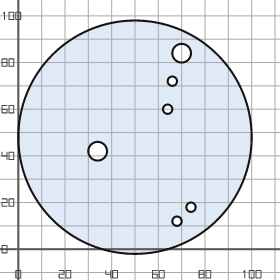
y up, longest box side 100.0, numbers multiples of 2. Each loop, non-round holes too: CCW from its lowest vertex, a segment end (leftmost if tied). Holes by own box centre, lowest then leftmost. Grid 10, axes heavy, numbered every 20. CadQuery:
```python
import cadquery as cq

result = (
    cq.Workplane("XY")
    .moveTo(50.0, 48.0)
    .circle(50.0)
    .moveTo(68.0, 12.0)
    .circle(2.0)
    .moveTo(74.0, 18.0)
    .circle(2.0)
    .moveTo(34.0, 42.0)
    .circle(4.0)
    .moveTo(64.0, 60.0)
    .circle(2.0)
    .moveTo(66.0, 72.0)
    .circle(2.0)
    .moveTo(70.0, 84.0)
    .circle(4.0)
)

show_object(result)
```